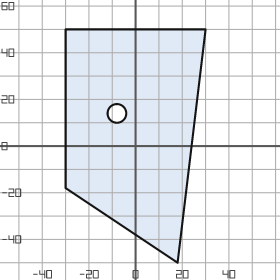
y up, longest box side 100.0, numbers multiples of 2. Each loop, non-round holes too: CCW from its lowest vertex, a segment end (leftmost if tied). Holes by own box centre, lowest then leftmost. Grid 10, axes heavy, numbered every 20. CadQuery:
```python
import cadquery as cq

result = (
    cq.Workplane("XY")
    .moveTo(18.0, -50.0)
    .lineTo(30.0, 50.0)
    .lineTo(-30.0, 50.0)
    .lineTo(-30.0, -18.0)
    .close()
    .moveTo(-8.0, 14.0)
    .circle(4.0)
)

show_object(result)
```